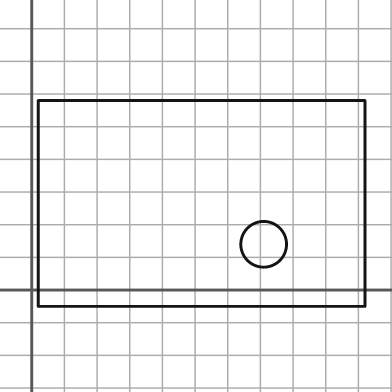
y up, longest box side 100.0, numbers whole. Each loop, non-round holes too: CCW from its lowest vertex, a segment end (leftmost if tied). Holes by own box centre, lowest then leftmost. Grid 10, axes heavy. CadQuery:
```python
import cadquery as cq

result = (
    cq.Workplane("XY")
    .moveTo(2.0, -5.0)
    .lineTo(102.0, -5.0)
    .lineTo(102.0, 58.0)
    .lineTo(2.0, 58.0)
    .close()
    .moveTo(71.0, 14.0)
    .circle(7.0)
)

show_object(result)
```